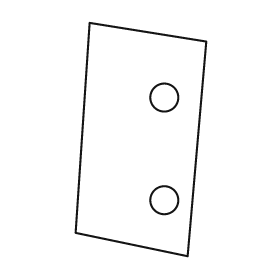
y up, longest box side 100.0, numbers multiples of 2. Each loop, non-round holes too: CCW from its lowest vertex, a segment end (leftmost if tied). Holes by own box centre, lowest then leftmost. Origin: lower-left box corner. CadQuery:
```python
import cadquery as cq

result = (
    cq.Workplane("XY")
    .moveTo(48.0, 0.0)
    .lineTo(56.0, 92.0)
    .lineTo(6.0, 100.0)
    .lineTo(0.0, 10.0)
    .close()
    .moveTo(38.0, 24.0)
    .circle(6.0)
    .moveTo(38.0, 68.0)
    .circle(6.0)
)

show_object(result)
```